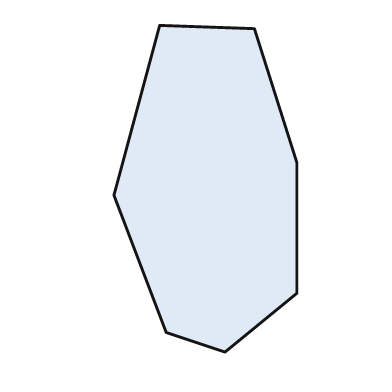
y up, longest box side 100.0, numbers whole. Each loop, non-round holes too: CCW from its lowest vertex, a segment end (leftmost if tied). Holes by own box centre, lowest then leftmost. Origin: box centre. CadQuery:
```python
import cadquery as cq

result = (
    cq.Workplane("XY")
    .moveTo(6.0, -50.0)
    .lineTo(28.0, -32.0)
    .lineTo(28.0, 8.0)
    .lineTo(15.0, 49.0)
    .lineTo(-14.0, 50.0)
    .lineTo(-28.0, -2.0)
    .lineTo(-12.0, -44.0)
    .close()
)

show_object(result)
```